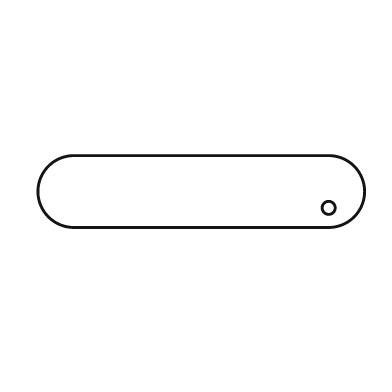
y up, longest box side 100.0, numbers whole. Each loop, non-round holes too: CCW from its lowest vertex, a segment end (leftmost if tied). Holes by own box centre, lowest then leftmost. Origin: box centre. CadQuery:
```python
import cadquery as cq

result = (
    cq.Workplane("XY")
    .moveTo(-39.0, -11.0)
    .lineTo(39.0, -11.0)
    .threePointArc((50.0, 0.0), (39.0, 11.0))
    .lineTo(-39.0, 11.0)
    .threePointArc((-50.0, 0.0), (-39.0, -11.0))
    .close()
    .moveTo(39.0, -5.0)
    .circle(2.0)
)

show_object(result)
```